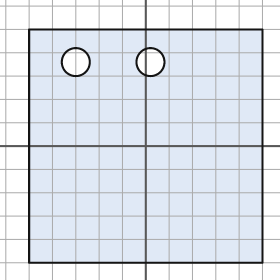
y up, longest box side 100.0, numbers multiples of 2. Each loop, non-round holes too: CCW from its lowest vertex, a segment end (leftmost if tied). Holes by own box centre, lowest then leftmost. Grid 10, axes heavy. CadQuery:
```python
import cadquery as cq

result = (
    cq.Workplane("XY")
    .moveTo(-50.0, -50.0)
    .lineTo(50.0, -50.0)
    .lineTo(50.0, 50.0)
    .lineTo(-50.0, 50.0)
    .close()
    .moveTo(-30.0, 36.0)
    .circle(6.0)
    .moveTo(2.0, 36.0)
    .circle(6.0)
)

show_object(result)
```